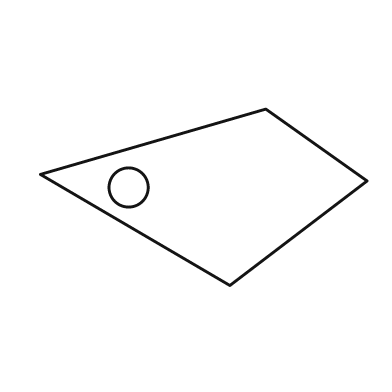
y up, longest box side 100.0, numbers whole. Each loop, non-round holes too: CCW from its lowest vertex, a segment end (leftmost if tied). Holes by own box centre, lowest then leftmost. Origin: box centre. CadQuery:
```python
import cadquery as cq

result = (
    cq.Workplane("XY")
    .moveTo(8.0, -27.0)
    .lineTo(50.0, 5.0)
    .lineTo(19.0, 27.0)
    .lineTo(-50.0, 7.0)
    .close()
    .moveTo(-23.0, 3.0)
    .circle(6.0)
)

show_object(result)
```